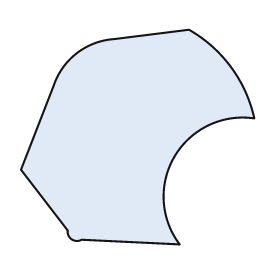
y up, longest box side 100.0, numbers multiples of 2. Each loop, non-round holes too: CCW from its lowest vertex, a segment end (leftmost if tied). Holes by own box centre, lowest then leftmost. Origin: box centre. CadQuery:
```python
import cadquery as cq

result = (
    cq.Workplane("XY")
    .moveTo(18.0, -46.0)
    .threePointArc((16.0, -8.0), (50.0, 8.0))
    .threePointArc((40.0, 30.0), (22.0, 46.0))
    .lineTo(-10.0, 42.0)
    .threePointArc((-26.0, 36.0), (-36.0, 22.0))
    .lineTo(-50.0, -14.0)
    .lineTo(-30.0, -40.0)
    .threePointArc((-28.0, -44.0), (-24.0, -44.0))
    .close()
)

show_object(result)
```